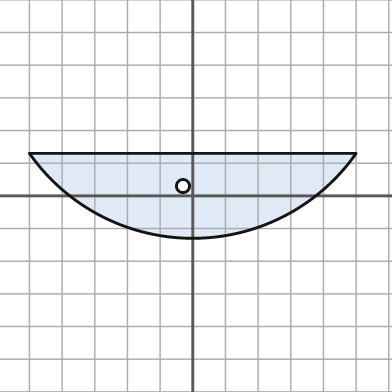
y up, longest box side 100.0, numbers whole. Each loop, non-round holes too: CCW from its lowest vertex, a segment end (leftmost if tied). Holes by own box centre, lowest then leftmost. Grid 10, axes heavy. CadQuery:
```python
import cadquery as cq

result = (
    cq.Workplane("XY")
    .moveTo(-50.0, 13.0)
    .threePointArc((0.0, -13.0), (50.0, 13.0))
    .close()
    .moveTo(-3.0, 3.0)
    .circle(2.0)
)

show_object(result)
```